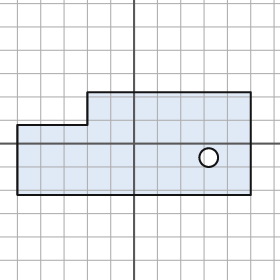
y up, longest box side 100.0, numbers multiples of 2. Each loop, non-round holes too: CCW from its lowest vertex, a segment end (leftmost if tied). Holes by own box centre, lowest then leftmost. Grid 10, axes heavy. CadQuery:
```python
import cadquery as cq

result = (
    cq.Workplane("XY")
    .moveTo(-50.0, -22.0)
    .lineTo(50.0, -22.0)
    .lineTo(50.0, 22.0)
    .lineTo(-20.0, 22.0)
    .lineTo(-20.0, 8.0)
    .lineTo(-50.0, 8.0)
    .close()
    .moveTo(32.0, -6.0)
    .circle(4.0)
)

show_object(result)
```